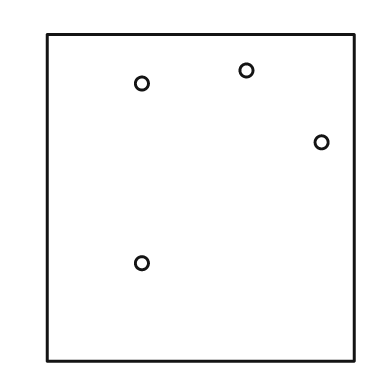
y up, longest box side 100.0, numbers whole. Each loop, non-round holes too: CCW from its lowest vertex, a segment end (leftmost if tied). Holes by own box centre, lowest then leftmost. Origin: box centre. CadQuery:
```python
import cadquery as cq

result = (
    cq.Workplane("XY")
    .moveTo(-47.0, -50.0)
    .lineTo(47.0, -50.0)
    .lineTo(47.0, 50.0)
    .lineTo(-47.0, 50.0)
    .close()
    .moveTo(-18.0, -20.0)
    .circle(2.0)
    .moveTo(37.0, 17.0)
    .circle(2.0)
    .moveTo(-18.0, 35.0)
    .circle(2.0)
    .moveTo(14.0, 39.0)
    .circle(2.0)
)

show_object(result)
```